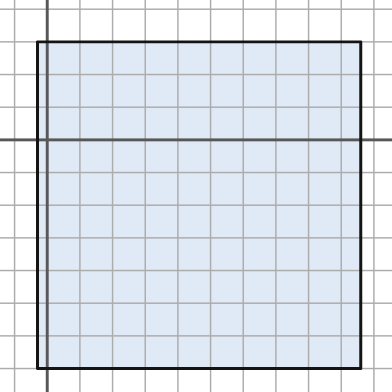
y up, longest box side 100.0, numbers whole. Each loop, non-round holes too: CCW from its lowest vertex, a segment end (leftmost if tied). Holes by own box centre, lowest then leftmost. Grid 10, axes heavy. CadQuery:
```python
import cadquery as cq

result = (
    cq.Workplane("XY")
    .moveTo(-3.0, -70.0)
    .lineTo(96.0, -70.0)
    .lineTo(96.0, 30.0)
    .lineTo(-3.0, 30.0)
    .close()
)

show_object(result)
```